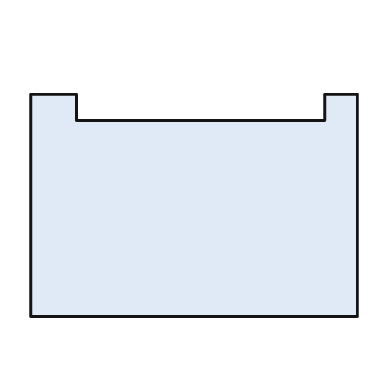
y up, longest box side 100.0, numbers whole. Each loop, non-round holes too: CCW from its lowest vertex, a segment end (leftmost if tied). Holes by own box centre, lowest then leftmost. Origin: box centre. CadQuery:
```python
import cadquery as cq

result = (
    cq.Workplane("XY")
    .moveTo(-50.0, -34.0)
    .lineTo(50.0, -34.0)
    .lineTo(50.0, 34.0)
    .lineTo(40.0, 34.0)
    .lineTo(40.0, 26.0)
    .lineTo(-36.0, 26.0)
    .lineTo(-36.0, 34.0)
    .lineTo(-50.0, 34.0)
    .close()
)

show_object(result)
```